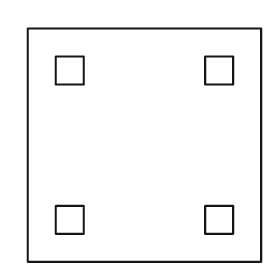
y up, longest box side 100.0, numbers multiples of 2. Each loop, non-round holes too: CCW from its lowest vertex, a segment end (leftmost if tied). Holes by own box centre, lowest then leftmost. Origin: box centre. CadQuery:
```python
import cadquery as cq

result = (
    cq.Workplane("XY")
    .moveTo(-50.0, -50.0)
    .lineTo(50.0, -50.0)
    .lineTo(50.0, 50.0)
    .lineTo(-50.0, 50.0)
    .close()
    .moveTo(-38.0, -38.0)
    .lineTo(-26.0, -38.0)
    .lineTo(-26.0, -26.0)
    .lineTo(-38.0, -26.0)
    .close()
    .moveTo(26.0, -38.0)
    .lineTo(38.0, -38.0)
    .lineTo(38.0, -26.0)
    .lineTo(26.0, -26.0)
    .close()
    .moveTo(-38.0, 26.0)
    .lineTo(-26.0, 26.0)
    .lineTo(-26.0, 38.0)
    .lineTo(-38.0, 38.0)
    .close()
    .moveTo(26.0, 26.0)
    .lineTo(38.0, 26.0)
    .lineTo(38.0, 38.0)
    .lineTo(26.0, 38.0)
    .close()
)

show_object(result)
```